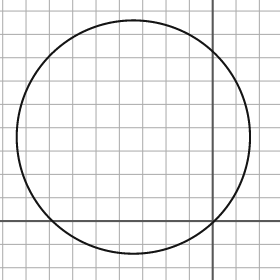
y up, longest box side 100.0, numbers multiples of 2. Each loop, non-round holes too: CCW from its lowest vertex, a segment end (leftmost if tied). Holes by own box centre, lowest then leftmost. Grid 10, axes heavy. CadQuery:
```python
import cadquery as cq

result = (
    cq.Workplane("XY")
    .moveTo(-34.0, 36.0)
    .circle(50.0)
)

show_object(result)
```